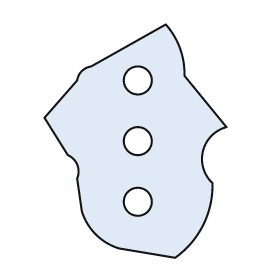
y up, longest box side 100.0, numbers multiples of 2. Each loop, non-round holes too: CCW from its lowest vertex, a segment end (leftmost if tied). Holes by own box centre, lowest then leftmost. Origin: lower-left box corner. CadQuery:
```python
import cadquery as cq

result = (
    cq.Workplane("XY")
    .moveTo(56.0, 0.0)
    .threePointArc((68.0, 14.0), (72.0, 32.0))
    .threePointArc((68.0, 46.0), (78.0, 56.0))
    .lineTo(60.0, 78.0)
    .threePointArc((58.0, 90.0), (52.0, 100.0))
    .lineTo(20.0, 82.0)
    .threePointArc((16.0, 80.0), (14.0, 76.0))
    .lineTo(0.0, 60.0)
    .lineTo(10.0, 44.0)
    .threePointArc((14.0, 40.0), (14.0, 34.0))
    .lineTo(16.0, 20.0)
    .threePointArc((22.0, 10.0), (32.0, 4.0))
    .close()
    .moveTo(40.0, 24.0)
    .circle(6.0)
    .moveTo(40.0, 50.0)
    .circle(6.0)
    .moveTo(40.0, 76.0)
    .circle(6.0)
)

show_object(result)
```